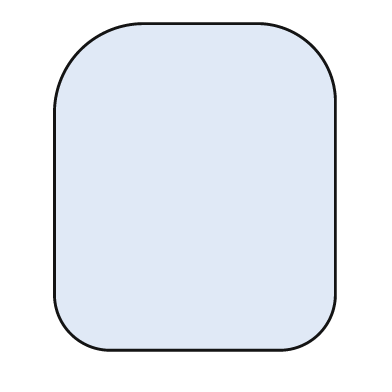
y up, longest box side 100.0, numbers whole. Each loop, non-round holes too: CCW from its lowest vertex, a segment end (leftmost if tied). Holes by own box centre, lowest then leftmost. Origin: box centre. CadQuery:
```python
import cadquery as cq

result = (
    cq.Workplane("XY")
    .moveTo(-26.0, -50.0)
    .lineTo(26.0, -50.0)
    .threePointArc((38.0, -45.0), (43.0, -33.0))
    .lineTo(43.0, 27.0)
    .threePointArc((36.0, 43.0), (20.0, 50.0))
    .lineTo(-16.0, 50.0)
    .threePointArc((-35.0, 42.0), (-43.0, 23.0))
    .lineTo(-43.0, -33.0)
    .threePointArc((-38.0, -45.0), (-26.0, -50.0))
    .close()
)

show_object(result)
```